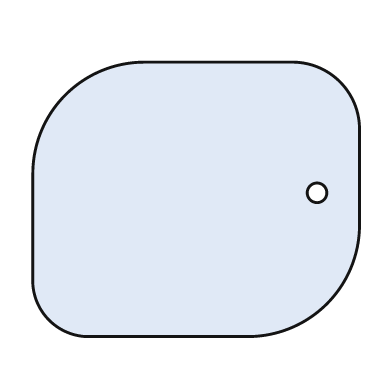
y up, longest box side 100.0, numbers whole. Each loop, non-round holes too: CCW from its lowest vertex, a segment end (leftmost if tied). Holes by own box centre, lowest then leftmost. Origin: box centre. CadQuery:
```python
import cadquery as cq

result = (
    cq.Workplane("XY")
    .moveTo(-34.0, -42.0)
    .lineTo(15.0, -42.0)
    .threePointArc((40.0, -32.0), (50.0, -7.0))
    .lineTo(50.0, 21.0)
    .threePointArc((44.0, 36.0), (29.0, 42.0))
    .lineTo(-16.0, 42.0)
    .threePointArc((-40.0, 32.0), (-50.0, 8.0))
    .lineTo(-50.0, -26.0)
    .threePointArc((-45.0, -37.0), (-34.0, -42.0))
    .close()
    .moveTo(37.0, 2.0)
    .circle(3.0)
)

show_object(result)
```